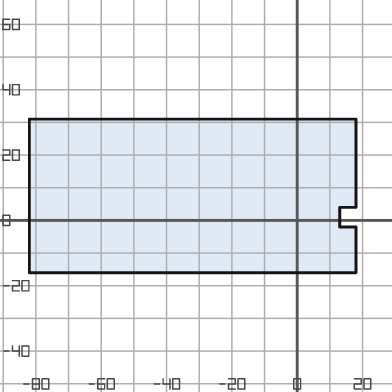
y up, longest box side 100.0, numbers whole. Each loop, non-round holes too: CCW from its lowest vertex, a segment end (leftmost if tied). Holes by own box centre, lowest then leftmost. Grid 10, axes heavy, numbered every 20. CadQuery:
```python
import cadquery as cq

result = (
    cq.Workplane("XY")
    .moveTo(-82.0, -16.0)
    .lineTo(18.0, -16.0)
    .lineTo(18.0, -2.0)
    .lineTo(13.0, -2.0)
    .lineTo(13.0, 4.0)
    .lineTo(18.0, 4.0)
    .lineTo(18.0, 31.0)
    .lineTo(-82.0, 31.0)
    .close()
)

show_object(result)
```